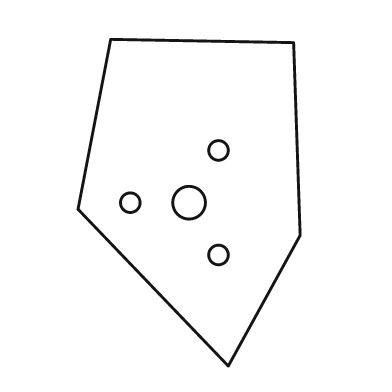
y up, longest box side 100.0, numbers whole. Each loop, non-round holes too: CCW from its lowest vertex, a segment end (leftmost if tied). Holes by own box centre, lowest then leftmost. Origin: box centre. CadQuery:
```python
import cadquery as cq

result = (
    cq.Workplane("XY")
    .moveTo(12.0, -50.0)
    .lineTo(34.0, -10.0)
    .lineTo(32.0, 49.0)
    .lineTo(-24.0, 50.0)
    .lineTo(-34.0, -2.0)
    .close()
    .moveTo(9.0, -16.0)
    .circle(3.0)
    .moveTo(-18.0, 0.0)
    .circle(3.0)
    .moveTo(0.0, 0.0)
    .circle(5.0)
    .moveTo(9.0, 16.0)
    .circle(3.0)
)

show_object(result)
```